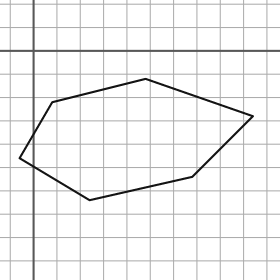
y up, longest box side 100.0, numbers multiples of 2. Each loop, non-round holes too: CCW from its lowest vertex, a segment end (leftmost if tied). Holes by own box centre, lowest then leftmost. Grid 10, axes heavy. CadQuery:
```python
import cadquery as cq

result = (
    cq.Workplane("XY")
    .moveTo(24.0, -64.0)
    .lineTo(68.0, -54.0)
    .lineTo(94.0, -28.0)
    .lineTo(48.0, -12.0)
    .lineTo(8.0, -22.0)
    .lineTo(-6.0, -46.0)
    .close()
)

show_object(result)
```